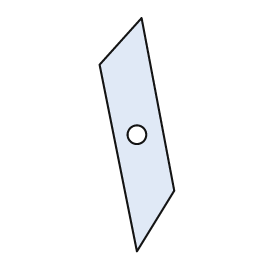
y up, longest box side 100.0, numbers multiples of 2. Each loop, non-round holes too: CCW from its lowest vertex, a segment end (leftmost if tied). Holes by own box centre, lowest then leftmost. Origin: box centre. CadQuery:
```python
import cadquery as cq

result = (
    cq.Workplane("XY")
    .moveTo(0.0, -50.0)
    .lineTo(16.0, -24.0)
    .lineTo(2.0, 50.0)
    .lineTo(-16.0, 30.0)
    .close()
    .moveTo(0.0, 0.0)
    .circle(4.0)
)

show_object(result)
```